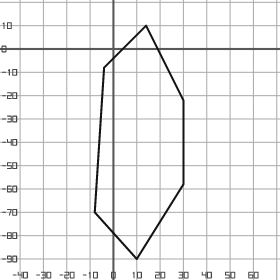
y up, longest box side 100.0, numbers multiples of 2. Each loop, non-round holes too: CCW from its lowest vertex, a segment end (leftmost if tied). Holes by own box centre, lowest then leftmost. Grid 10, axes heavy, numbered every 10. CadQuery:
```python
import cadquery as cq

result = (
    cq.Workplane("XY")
    .moveTo(10.0, -90.0)
    .lineTo(30.0, -58.0)
    .lineTo(30.0, -22.0)
    .lineTo(14.0, 10.0)
    .lineTo(-4.0, -8.0)
    .lineTo(-8.0, -70.0)
    .close()
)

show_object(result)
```